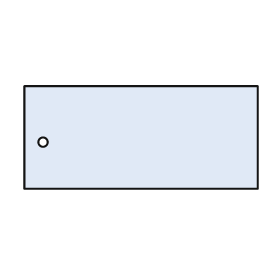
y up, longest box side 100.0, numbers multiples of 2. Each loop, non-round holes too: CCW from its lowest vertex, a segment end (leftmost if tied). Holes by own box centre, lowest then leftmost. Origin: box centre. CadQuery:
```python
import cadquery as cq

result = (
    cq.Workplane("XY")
    .moveTo(-50.0, -22.0)
    .lineTo(50.0, -22.0)
    .lineTo(50.0, 22.0)
    .lineTo(-50.0, 22.0)
    .close()
    .moveTo(-42.0, -2.0)
    .circle(2.0)
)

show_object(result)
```